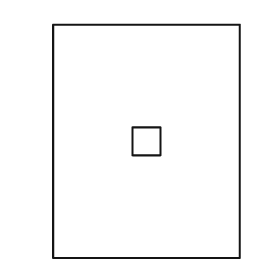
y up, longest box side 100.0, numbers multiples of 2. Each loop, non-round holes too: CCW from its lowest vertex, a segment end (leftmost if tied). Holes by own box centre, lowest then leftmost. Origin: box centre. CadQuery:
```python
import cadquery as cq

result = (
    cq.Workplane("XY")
    .moveTo(-40.0, -50.0)
    .lineTo(40.0, -50.0)
    .lineTo(40.0, 50.0)
    .lineTo(-40.0, 50.0)
    .close()
    .moveTo(-6.0, -6.0)
    .lineTo(6.0, -6.0)
    .lineTo(6.0, 6.0)
    .lineTo(-6.0, 6.0)
    .close()
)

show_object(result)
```